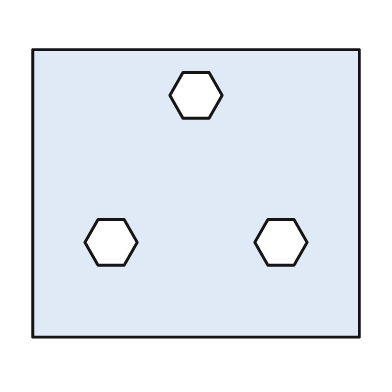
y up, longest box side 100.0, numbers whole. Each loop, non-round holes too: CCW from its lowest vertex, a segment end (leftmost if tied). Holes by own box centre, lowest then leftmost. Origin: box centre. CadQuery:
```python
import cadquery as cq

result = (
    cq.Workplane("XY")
    .moveTo(-50.0, -44.0)
    .lineTo(50.0, -44.0)
    .lineTo(50.0, 44.0)
    .lineTo(-50.0, 44.0)
    .close()
    .moveTo(-30.0, -22.0)
    .lineTo(-22.0, -22.0)
    .lineTo(-18.0, -15.0)
    .lineTo(-22.0, -8.0)
    .lineTo(-30.0, -8.0)
    .lineTo(-34.0, -15.0)
    .close()
    .moveTo(22.0, -22.0)
    .lineTo(30.0, -22.0)
    .lineTo(34.0, -15.0)
    .lineTo(30.0, -8.0)
    .lineTo(22.0, -8.0)
    .lineTo(18.0, -15.0)
    .close()
    .moveTo(-4.0, 23.0)
    .lineTo(4.0, 23.0)
    .lineTo(8.0, 30.0)
    .lineTo(4.0, 37.0)
    .lineTo(-4.0, 37.0)
    .lineTo(-8.0, 30.0)
    .close()
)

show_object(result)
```